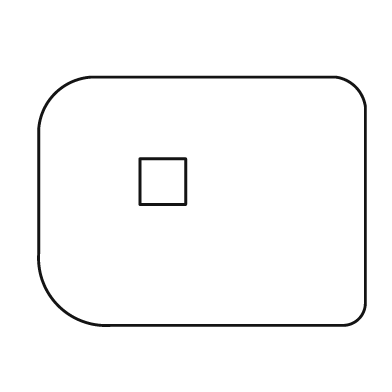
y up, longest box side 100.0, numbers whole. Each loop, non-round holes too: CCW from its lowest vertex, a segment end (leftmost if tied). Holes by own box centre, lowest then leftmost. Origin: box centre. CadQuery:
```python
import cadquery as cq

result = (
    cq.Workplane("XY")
    .moveTo(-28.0, -38.0)
    .lineTo(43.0, -38.0)
    .threePointArc((48.0, -36.0), (50.0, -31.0))
    .lineTo(50.0, 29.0)
    .threePointArc((47.0, 35.0), (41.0, 38.0))
    .lineTo(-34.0, 38.0)
    .threePointArc((-45.0, 33.0), (-50.0, 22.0))
    .lineTo(-50.0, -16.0)
    .threePointArc((-44.0, -32.0), (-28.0, -38.0))
    .close()
    .moveTo(-19.0, -1.0)
    .lineTo(-5.0, -1.0)
    .lineTo(-5.0, 13.0)
    .lineTo(-19.0, 13.0)
    .close()
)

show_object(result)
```